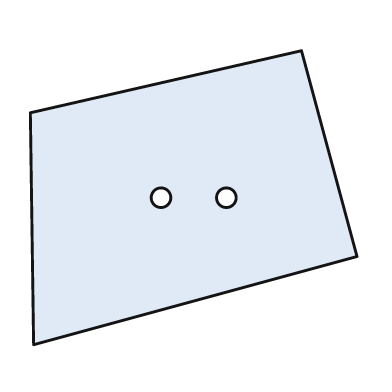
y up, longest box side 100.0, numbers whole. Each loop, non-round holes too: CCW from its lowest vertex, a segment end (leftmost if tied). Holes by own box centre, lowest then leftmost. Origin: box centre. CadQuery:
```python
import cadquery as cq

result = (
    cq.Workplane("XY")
    .moveTo(-49.0, -45.0)
    .lineTo(50.0, -18.0)
    .lineTo(33.0, 45.0)
    .lineTo(-50.0, 26.0)
    .close()
    .moveTo(-10.0, 0.0)
    .circle(3.0)
    .moveTo(10.0, 0.0)
    .circle(3.0)
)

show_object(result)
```